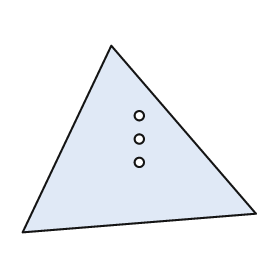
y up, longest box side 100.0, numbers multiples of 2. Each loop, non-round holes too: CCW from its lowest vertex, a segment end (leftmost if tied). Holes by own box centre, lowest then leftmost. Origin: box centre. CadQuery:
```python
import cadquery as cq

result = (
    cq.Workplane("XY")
    .moveTo(-50.0, -40.0)
    .lineTo(50.0, -32.0)
    .lineTo(-12.0, 40.0)
    .close()
    .moveTo(0.0, -10.0)
    .circle(2.0)
    .moveTo(0.0, 0.0)
    .circle(2.0)
    .moveTo(0.0, 10.0)
    .circle(2.0)
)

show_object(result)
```